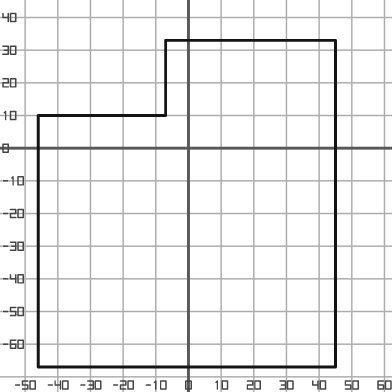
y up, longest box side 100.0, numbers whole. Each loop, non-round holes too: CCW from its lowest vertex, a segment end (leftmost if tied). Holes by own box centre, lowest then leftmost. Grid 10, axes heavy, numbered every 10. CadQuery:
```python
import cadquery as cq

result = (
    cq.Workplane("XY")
    .moveTo(-46.0, -67.0)
    .lineTo(45.0, -67.0)
    .lineTo(45.0, 33.0)
    .lineTo(-7.0, 33.0)
    .lineTo(-7.0, 10.0)
    .lineTo(-46.0, 10.0)
    .close()
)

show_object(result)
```